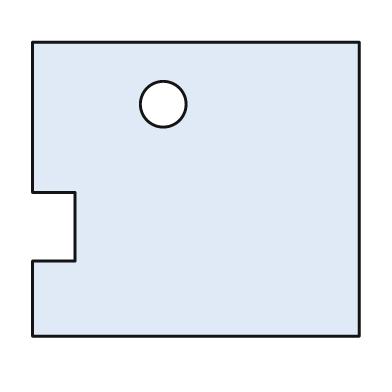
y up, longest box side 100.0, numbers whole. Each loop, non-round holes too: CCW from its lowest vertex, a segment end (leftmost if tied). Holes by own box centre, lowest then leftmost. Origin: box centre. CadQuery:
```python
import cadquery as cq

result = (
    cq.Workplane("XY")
    .moveTo(-50.0, -45.0)
    .lineTo(50.0, -45.0)
    .lineTo(50.0, 45.0)
    .lineTo(-50.0, 45.0)
    .lineTo(-50.0, -1.0)
    .lineTo(-37.0, -1.0)
    .lineTo(-37.0, -22.0)
    .lineTo(-50.0, -22.0)
    .close()
    .moveTo(-10.0, 26.0)
    .circle(7.0)
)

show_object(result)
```